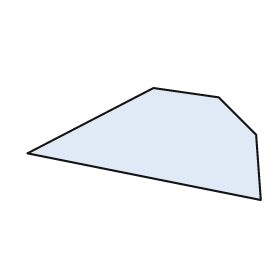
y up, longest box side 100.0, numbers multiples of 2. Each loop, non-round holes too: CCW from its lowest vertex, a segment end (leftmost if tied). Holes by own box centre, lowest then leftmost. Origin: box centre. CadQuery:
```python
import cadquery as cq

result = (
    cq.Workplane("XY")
    .moveTo(50.0, -24.0)
    .lineTo(48.0, 4.0)
    .lineTo(32.0, 20.0)
    .lineTo(4.0, 24.0)
    .lineTo(-50.0, -4.0)
    .close()
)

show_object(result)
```